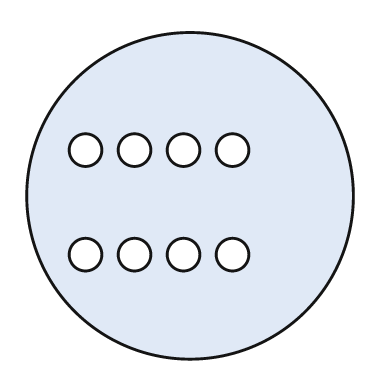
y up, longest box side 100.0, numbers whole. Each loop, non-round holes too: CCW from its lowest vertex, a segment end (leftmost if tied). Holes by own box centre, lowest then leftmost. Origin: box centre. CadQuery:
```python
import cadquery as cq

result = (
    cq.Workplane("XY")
    .moveTo(0.0, 0.0)
    .circle(50.0)
    .moveTo(-32.0, -18.0)
    .circle(5.0)
    .moveTo(-17.0, -18.0)
    .circle(5.0)
    .moveTo(-2.0, -18.0)
    .circle(5.0)
    .moveTo(13.0, -18.0)
    .circle(5.0)
    .moveTo(-32.0, 14.0)
    .circle(5.0)
    .moveTo(-17.0, 14.0)
    .circle(5.0)
    .moveTo(-2.0, 14.0)
    .circle(5.0)
    .moveTo(13.0, 14.0)
    .circle(5.0)
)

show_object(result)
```